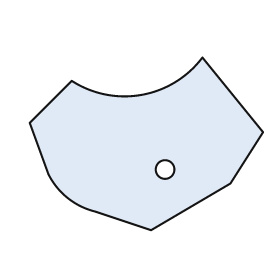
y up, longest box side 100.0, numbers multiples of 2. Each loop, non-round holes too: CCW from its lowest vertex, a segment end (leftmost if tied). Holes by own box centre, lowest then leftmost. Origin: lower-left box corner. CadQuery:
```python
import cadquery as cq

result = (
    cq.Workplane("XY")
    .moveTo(52.0, 0.0)
    .lineTo(86.0, 20.0)
    .lineTo(100.0, 42.0)
    .lineTo(74.0, 74.0)
    .threePointArc((48.0, 58.0), (18.0, 64.0))
    .lineTo(0.0, 46.0)
    .lineTo(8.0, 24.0)
    .threePointArc((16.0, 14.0), (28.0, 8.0))
    .close()
    .moveTo(58.0, 26.0)
    .circle(4.0)
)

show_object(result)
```